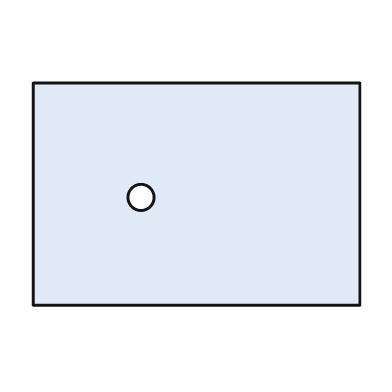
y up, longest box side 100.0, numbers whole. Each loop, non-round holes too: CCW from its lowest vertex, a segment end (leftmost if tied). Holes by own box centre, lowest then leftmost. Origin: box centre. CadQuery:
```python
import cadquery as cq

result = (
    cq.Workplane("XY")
    .moveTo(-50.0, -34.0)
    .lineTo(50.0, -34.0)
    .lineTo(50.0, 34.0)
    .lineTo(-50.0, 34.0)
    .close()
    .moveTo(-17.0, -1.0)
    .circle(4.0)
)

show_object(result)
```